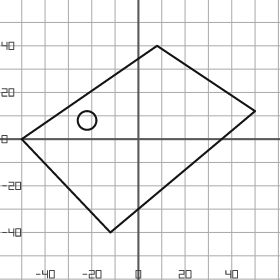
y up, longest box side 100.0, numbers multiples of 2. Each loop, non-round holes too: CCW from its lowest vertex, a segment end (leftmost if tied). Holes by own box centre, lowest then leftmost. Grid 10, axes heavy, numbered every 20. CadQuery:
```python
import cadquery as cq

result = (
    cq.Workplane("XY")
    .moveTo(-12.0, -40.0)
    .lineTo(50.0, 12.0)
    .lineTo(8.0, 40.0)
    .lineTo(-50.0, 0.0)
    .close()
    .moveTo(-22.0, 8.0)
    .circle(4.0)
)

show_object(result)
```